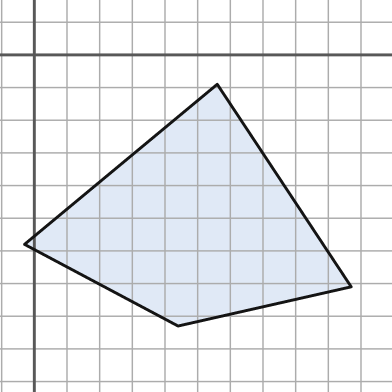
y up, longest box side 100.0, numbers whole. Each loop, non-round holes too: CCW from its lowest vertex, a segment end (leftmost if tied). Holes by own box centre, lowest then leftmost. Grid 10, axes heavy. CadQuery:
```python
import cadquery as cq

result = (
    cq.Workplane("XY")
    .moveTo(44.0, -83.0)
    .lineTo(97.0, -71.0)
    .lineTo(56.0, -9.0)
    .lineTo(-3.0, -58.0)
    .close()
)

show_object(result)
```